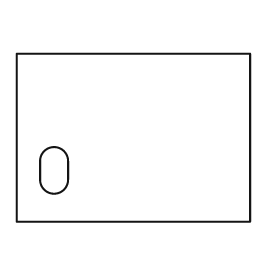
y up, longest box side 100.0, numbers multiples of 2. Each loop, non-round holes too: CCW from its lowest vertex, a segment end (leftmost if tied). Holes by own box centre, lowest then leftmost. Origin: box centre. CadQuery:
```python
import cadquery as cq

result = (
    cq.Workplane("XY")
    .moveTo(-50.0, -36.0)
    .lineTo(50.0, -36.0)
    .lineTo(50.0, 36.0)
    .lineTo(-50.0, 36.0)
    .close()
    .moveTo(-40.0, -18.0)
    .threePointArc((-34.0, -24.0), (-28.0, -18.0))
    .lineTo(-28.0, -10.0)
    .threePointArc((-34.0, -4.0), (-40.0, -10.0))
    .close()
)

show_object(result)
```